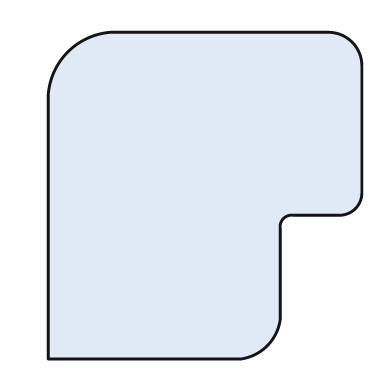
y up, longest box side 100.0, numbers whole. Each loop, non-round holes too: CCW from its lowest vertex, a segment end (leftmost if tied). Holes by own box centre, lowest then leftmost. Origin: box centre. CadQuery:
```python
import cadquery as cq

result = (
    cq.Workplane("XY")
    .moveTo(-48.0, -50.0)
    .lineTo(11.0, -50.0)
    .threePointArc((19.0, -46.0), (23.0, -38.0))
    .lineTo(23.0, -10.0)
    .threePointArc((24.0, -7.0), (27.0, -6.0))
    .lineTo(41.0, -6.0)
    .threePointArc((46.0, -4.0), (48.0, 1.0))
    .lineTo(48.0, 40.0)
    .threePointArc((45.0, 47.0), (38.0, 50.0))
    .lineTo(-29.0, 50.0)
    .threePointArc((-42.0, 44.0), (-48.0, 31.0))
    .close()
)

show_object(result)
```